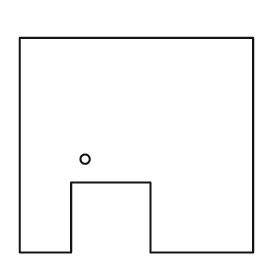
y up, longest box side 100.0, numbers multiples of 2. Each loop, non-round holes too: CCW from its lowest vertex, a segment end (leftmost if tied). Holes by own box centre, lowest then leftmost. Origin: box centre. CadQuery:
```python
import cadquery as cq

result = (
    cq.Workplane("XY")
    .moveTo(-50.0, -46.0)
    .lineTo(-28.0, -46.0)
    .lineTo(-28.0, -16.0)
    .lineTo(6.0, -16.0)
    .lineTo(6.0, -46.0)
    .lineTo(50.0, -46.0)
    .lineTo(50.0, 46.0)
    .lineTo(-50.0, 46.0)
    .close()
    .moveTo(-22.0, -6.0)
    .circle(2.0)
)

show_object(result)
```